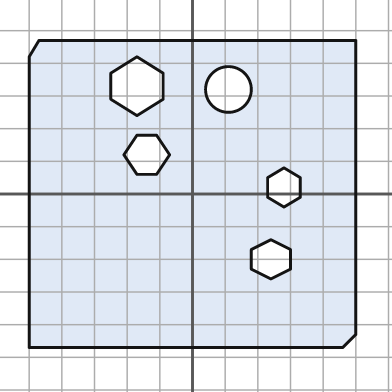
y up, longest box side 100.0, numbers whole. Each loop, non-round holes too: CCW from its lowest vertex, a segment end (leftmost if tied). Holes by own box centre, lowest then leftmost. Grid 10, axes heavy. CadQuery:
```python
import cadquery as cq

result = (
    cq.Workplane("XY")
    .moveTo(-50.0, -47.0)
    .lineTo(46.0, -47.0)
    .lineTo(50.0, -43.0)
    .lineTo(50.0, 47.0)
    .lineTo(-47.0, 47.0)
    .lineTo(-50.0, 42.0)
    .close()
    .moveTo(24.0, -26.0)
    .lineTo(30.0, -23.0)
    .lineTo(30.0, -17.0)
    .lineTo(24.0, -14.0)
    .lineTo(18.0, -17.0)
    .lineTo(18.0, -23.0)
    .close()
    .moveTo(28.0, -4.0)
    .lineTo(33.0, -1.0)
    .lineTo(33.0, 5.0)
    .lineTo(28.0, 8.0)
    .lineTo(23.0, 5.0)
    .lineTo(23.0, -1.0)
    .close()
    .moveTo(-17.0, 6.0)
    .lineTo(-11.0, 6.0)
    .lineTo(-7.0, 12.0)
    .lineTo(-11.0, 18.0)
    .lineTo(-17.0, 18.0)
    .lineTo(-21.0, 12.0)
    .close()
    .moveTo(11.0, 32.0)
    .circle(7.0)
    .moveTo(-17.0, 24.0)
    .lineTo(-9.0, 29.0)
    .lineTo(-9.0, 37.0)
    .lineTo(-17.0, 42.0)
    .lineTo(-25.0, 37.0)
    .lineTo(-25.0, 29.0)
    .close()
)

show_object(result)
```